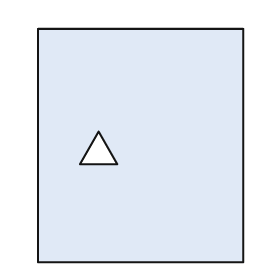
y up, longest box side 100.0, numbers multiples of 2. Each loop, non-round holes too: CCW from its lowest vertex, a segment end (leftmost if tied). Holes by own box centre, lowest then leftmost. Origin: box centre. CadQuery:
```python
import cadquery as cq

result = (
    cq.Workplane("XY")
    .moveTo(-44.0, -50.0)
    .lineTo(44.0, -50.0)
    .lineTo(44.0, 50.0)
    .lineTo(-44.0, 50.0)
    .close()
    .moveTo(-26.0, -8.0)
    .lineTo(-10.0, -8.0)
    .lineTo(-18.0, 6.0)
    .close()
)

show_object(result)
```